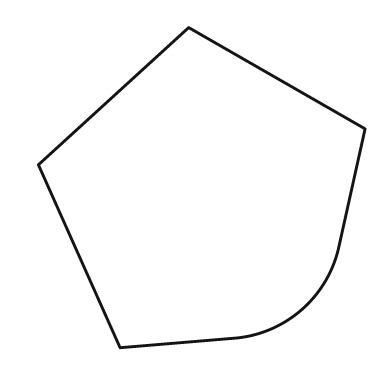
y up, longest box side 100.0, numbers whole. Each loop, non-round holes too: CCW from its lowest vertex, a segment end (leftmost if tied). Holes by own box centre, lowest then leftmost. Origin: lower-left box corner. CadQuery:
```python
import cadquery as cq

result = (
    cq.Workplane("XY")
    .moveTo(25.0, 0.0)
    .lineTo(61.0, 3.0)
    .threePointArc((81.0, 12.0), (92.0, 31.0))
    .lineTo(100.0, 67.0)
    .lineTo(46.0, 98.0)
    .lineTo(0.0, 56.0)
    .close()
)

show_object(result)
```